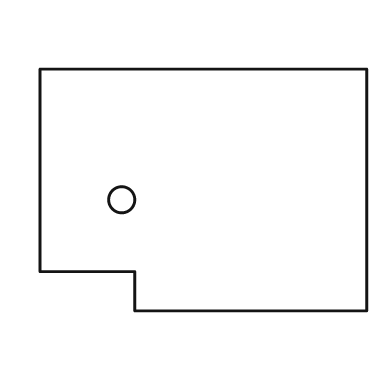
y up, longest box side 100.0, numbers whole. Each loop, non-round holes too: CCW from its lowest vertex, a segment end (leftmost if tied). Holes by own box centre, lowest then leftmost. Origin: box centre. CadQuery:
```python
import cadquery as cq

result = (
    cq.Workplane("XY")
    .moveTo(-21.0, -37.0)
    .lineTo(50.0, -37.0)
    .lineTo(50.0, 37.0)
    .lineTo(-50.0, 37.0)
    .lineTo(-50.0, -25.0)
    .lineTo(-21.0, -25.0)
    .close()
    .moveTo(-25.0, -3.0)
    .circle(4.0)
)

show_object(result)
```